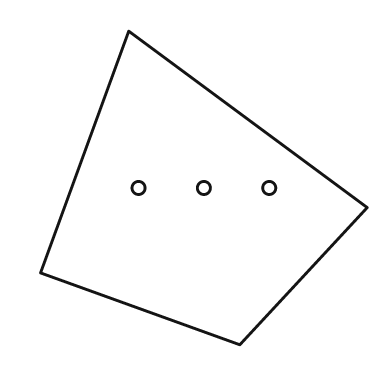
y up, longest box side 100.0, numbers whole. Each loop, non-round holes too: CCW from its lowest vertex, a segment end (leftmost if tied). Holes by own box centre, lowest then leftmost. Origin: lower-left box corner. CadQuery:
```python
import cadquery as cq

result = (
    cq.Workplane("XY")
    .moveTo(61.0, 0.0)
    .lineTo(100.0, 42.0)
    .lineTo(27.0, 96.0)
    .lineTo(0.0, 22.0)
    .close()
    .moveTo(30.0, 48.0)
    .circle(2.0)
    .moveTo(50.0, 48.0)
    .circle(2.0)
    .moveTo(70.0, 48.0)
    .circle(2.0)
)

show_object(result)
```